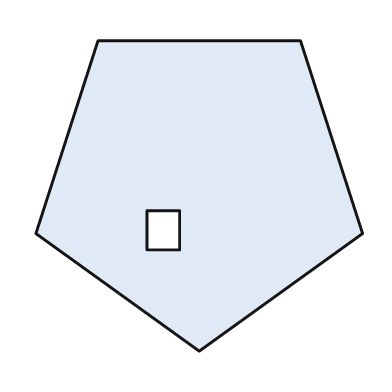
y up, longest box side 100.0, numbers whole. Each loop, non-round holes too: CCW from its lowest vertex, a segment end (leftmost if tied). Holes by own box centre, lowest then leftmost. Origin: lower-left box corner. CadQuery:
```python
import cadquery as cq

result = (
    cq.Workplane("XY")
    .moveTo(50.0, 0.0)
    .lineTo(100.0, 36.0)
    .lineTo(81.0, 95.0)
    .lineTo(19.0, 95.0)
    .lineTo(0.0, 36.0)
    .close()
    .moveTo(34.0, 31.0)
    .lineTo(44.0, 31.0)
    .lineTo(44.0, 43.0)
    .lineTo(34.0, 43.0)
    .close()
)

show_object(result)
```